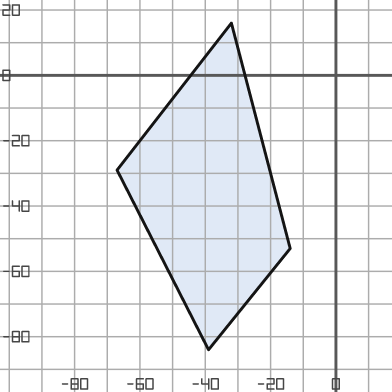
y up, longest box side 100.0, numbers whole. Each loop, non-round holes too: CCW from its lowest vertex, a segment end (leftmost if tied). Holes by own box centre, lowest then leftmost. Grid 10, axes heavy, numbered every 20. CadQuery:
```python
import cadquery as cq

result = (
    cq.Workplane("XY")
    .moveTo(-39.0, -84.0)
    .lineTo(-14.0, -53.0)
    .lineTo(-32.0, 16.0)
    .lineTo(-67.0, -29.0)
    .close()
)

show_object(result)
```